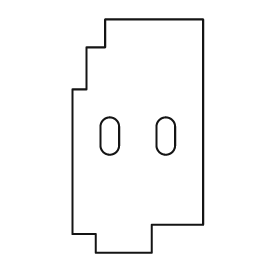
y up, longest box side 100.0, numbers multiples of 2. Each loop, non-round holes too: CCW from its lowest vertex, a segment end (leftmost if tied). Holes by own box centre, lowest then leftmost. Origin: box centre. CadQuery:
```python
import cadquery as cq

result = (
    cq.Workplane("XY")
    .moveTo(-18.0, -50.0)
    .lineTo(6.0, -50.0)
    .lineTo(6.0, -38.0)
    .lineTo(28.0, -38.0)
    .lineTo(28.0, 50.0)
    .lineTo(-14.0, 50.0)
    .lineTo(-14.0, 38.0)
    .lineTo(-22.0, 38.0)
    .lineTo(-22.0, 20.0)
    .lineTo(-28.0, 20.0)
    .lineTo(-28.0, -42.0)
    .lineTo(-18.0, -42.0)
    .close()
    .moveTo(-16.0, -4.0)
    .threePointArc((-12.0, -8.0), (-8.0, -4.0))
    .lineTo(-8.0, 4.0)
    .threePointArc((-12.0, 8.0), (-16.0, 4.0))
    .close()
    .moveTo(8.0, -4.0)
    .threePointArc((12.0, -8.0), (16.0, -4.0))
    .lineTo(16.0, 4.0)
    .threePointArc((12.0, 8.0), (8.0, 4.0))
    .close()
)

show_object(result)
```